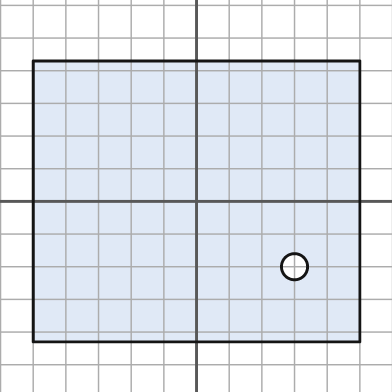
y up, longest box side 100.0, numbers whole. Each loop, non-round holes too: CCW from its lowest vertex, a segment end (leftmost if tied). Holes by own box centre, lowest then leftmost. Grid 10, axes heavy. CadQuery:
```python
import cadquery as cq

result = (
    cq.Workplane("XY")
    .moveTo(-50.0, -43.0)
    .lineTo(50.0, -43.0)
    .lineTo(50.0, 43.0)
    .lineTo(-50.0, 43.0)
    .close()
    .moveTo(30.0, -20.0)
    .circle(4.0)
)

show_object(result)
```